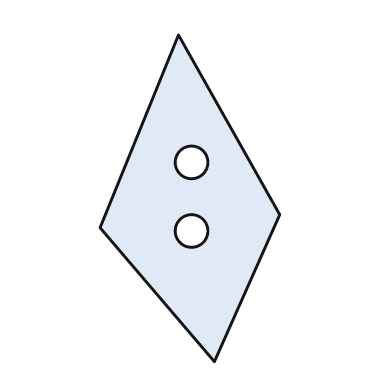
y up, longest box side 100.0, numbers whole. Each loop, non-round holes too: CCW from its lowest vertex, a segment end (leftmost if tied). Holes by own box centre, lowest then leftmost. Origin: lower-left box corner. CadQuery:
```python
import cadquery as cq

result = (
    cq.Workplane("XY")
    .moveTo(35.0, 0.0)
    .lineTo(55.0, 45.0)
    .lineTo(24.0, 100.0)
    .lineTo(0.0, 41.0)
    .close()
    .moveTo(28.0, 40.0)
    .circle(5.0)
    .moveTo(28.0, 61.0)
    .circle(5.0)
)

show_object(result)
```